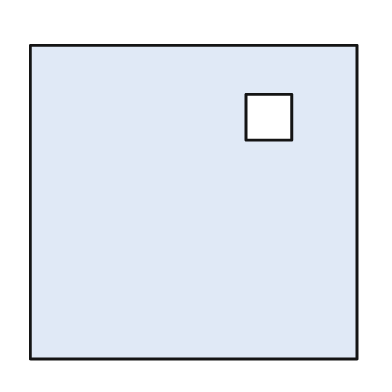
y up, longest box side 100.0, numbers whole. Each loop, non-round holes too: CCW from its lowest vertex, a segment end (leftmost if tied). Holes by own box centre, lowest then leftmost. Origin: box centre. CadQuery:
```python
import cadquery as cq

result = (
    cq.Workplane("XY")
    .moveTo(-50.0, -48.0)
    .lineTo(50.0, -48.0)
    .lineTo(50.0, 48.0)
    .lineTo(-50.0, 48.0)
    .close()
    .moveTo(16.0, 19.0)
    .lineTo(30.0, 19.0)
    .lineTo(30.0, 33.0)
    .lineTo(16.0, 33.0)
    .close()
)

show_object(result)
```